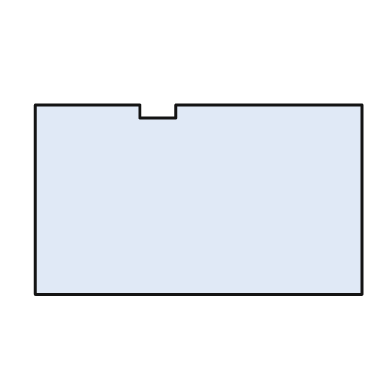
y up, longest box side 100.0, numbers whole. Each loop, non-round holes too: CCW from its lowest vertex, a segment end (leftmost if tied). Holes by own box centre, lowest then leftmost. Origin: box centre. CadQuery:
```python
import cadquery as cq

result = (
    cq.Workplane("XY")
    .moveTo(-50.0, -29.0)
    .lineTo(50.0, -29.0)
    .lineTo(50.0, 29.0)
    .lineTo(-7.0, 29.0)
    .lineTo(-7.0, 25.0)
    .lineTo(-18.0, 25.0)
    .lineTo(-18.0, 29.0)
    .lineTo(-50.0, 29.0)
    .close()
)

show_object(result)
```